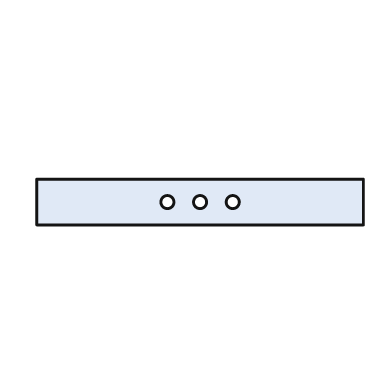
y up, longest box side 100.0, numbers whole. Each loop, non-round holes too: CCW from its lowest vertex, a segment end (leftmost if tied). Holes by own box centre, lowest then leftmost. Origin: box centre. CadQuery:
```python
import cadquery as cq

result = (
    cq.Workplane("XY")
    .moveTo(-50.0, -7.0)
    .lineTo(50.0, -7.0)
    .lineTo(50.0, 7.0)
    .lineTo(-50.0, 7.0)
    .close()
    .moveTo(-10.0, 0.0)
    .circle(2.0)
    .moveTo(0.0, 0.0)
    .circle(2.0)
    .moveTo(10.0, 0.0)
    .circle(2.0)
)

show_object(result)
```